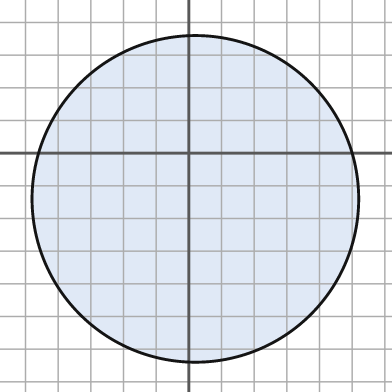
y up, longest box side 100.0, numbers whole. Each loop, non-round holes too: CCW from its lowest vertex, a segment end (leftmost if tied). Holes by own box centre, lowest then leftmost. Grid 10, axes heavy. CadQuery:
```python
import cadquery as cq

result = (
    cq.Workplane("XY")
    .moveTo(2.0, -14.0)
    .circle(50.0)
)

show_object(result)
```